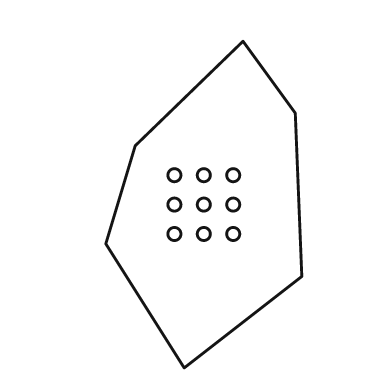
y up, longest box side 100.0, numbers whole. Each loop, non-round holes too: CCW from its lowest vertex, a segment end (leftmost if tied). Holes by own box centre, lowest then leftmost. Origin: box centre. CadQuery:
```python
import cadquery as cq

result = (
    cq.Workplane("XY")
    .moveTo(-6.0, -50.0)
    .lineTo(30.0, -22.0)
    .lineTo(28.0, 28.0)
    .lineTo(12.0, 50.0)
    .lineTo(-21.0, 18.0)
    .lineTo(-30.0, -12.0)
    .close()
    .moveTo(-9.0, -9.0)
    .circle(2.0)
    .moveTo(0.0, -9.0)
    .circle(2.0)
    .moveTo(9.0, -9.0)
    .circle(2.0)
    .moveTo(-9.0, 0.0)
    .circle(2.0)
    .moveTo(0.0, 0.0)
    .circle(2.0)
    .moveTo(9.0, 0.0)
    .circle(2.0)
    .moveTo(-9.0, 9.0)
    .circle(2.0)
    .moveTo(0.0, 9.0)
    .circle(2.0)
    .moveTo(9.0, 9.0)
    .circle(2.0)
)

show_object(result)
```